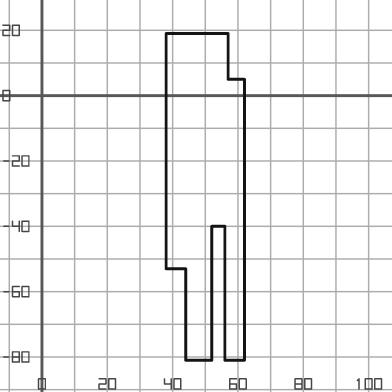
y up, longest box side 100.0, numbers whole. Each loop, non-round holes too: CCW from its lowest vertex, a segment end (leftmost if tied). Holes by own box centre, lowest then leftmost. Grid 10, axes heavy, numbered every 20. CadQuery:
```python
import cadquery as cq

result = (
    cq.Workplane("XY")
    .moveTo(44.0, -81.0)
    .lineTo(52.0, -81.0)
    .lineTo(52.0, -40.0)
    .lineTo(56.0, -40.0)
    .lineTo(56.0, -81.0)
    .lineTo(62.0, -81.0)
    .lineTo(62.0, 5.0)
    .lineTo(57.0, 5.0)
    .lineTo(57.0, 19.0)
    .lineTo(38.0, 19.0)
    .lineTo(38.0, -53.0)
    .lineTo(44.0, -53.0)
    .close()
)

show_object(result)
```